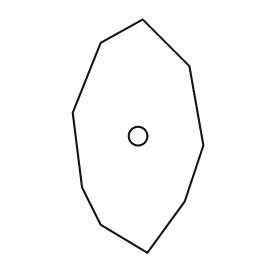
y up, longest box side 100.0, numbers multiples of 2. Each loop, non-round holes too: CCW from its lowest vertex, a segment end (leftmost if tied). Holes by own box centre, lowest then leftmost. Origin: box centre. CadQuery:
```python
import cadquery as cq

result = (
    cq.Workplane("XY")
    .moveTo(4.0, -50.0)
    .lineTo(20.0, -28.0)
    .lineTo(28.0, -4.0)
    .lineTo(22.0, 30.0)
    .lineTo(2.0, 50.0)
    .lineTo(-16.0, 40.0)
    .lineTo(-28.0, 10.0)
    .lineTo(-24.0, -22.0)
    .lineTo(-16.0, -38.0)
    .close()
    .moveTo(0.0, 0.0)
    .circle(4.0)
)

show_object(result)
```